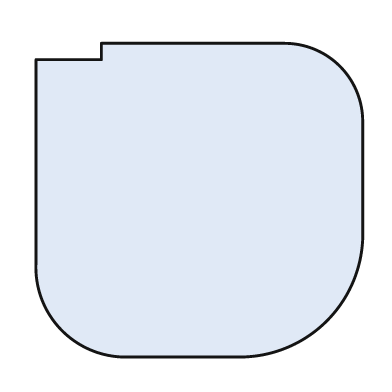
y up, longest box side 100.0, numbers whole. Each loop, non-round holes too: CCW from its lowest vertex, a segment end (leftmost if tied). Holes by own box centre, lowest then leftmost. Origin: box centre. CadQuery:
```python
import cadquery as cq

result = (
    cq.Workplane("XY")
    .moveTo(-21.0, -48.0)
    .lineTo(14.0, -48.0)
    .threePointArc((39.0, -37.0), (50.0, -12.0))
    .lineTo(50.0, 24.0)
    .threePointArc((43.0, 41.0), (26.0, 48.0))
    .lineTo(-30.0, 48.0)
    .lineTo(-30.0, 43.0)
    .lineTo(-50.0, 43.0)
    .lineTo(-50.0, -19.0)
    .threePointArc((-42.0, -40.0), (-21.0, -48.0))
    .close()
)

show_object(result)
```